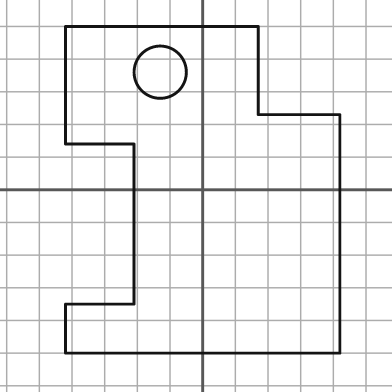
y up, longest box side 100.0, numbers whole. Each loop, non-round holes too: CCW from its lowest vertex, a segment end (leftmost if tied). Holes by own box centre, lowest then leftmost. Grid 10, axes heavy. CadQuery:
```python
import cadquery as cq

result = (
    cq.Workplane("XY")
    .moveTo(-42.0, -50.0)
    .lineTo(42.0, -50.0)
    .lineTo(42.0, 23.0)
    .lineTo(17.0, 23.0)
    .lineTo(17.0, 50.0)
    .lineTo(-42.0, 50.0)
    .lineTo(-42.0, 14.0)
    .lineTo(-21.0, 14.0)
    .lineTo(-21.0, -35.0)
    .lineTo(-42.0, -35.0)
    .close()
    .moveTo(-13.0, 36.0)
    .circle(8.0)
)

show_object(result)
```